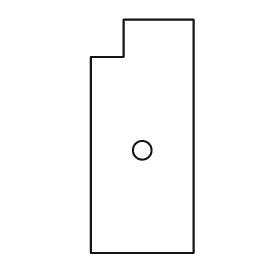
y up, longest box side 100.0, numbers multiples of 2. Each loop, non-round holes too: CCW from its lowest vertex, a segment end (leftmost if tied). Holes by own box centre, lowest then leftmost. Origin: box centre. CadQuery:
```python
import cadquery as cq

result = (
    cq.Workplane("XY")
    .moveTo(-22.0, -50.0)
    .lineTo(22.0, -50.0)
    .lineTo(22.0, 50.0)
    .lineTo(-8.0, 50.0)
    .lineTo(-8.0, 34.0)
    .lineTo(-22.0, 34.0)
    .close()
    .moveTo(0.0, -6.0)
    .circle(4.0)
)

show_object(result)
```